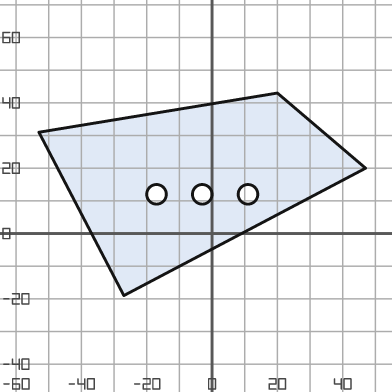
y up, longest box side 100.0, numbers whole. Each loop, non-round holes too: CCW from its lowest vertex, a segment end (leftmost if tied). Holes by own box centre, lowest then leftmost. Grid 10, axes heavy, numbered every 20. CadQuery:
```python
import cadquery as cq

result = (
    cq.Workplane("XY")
    .moveTo(-27.0, -19.0)
    .lineTo(47.0, 20.0)
    .lineTo(20.0, 43.0)
    .lineTo(-53.0, 31.0)
    .close()
    .moveTo(-17.0, 12.0)
    .circle(3.0)
    .moveTo(-3.0, 12.0)
    .circle(3.0)
    .moveTo(11.0, 12.0)
    .circle(3.0)
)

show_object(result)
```